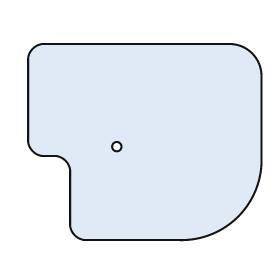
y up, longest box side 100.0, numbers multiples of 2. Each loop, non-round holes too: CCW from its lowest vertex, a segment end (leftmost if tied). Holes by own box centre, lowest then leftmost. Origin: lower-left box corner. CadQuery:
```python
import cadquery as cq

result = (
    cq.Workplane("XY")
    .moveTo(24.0, 0.0)
    .lineTo(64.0, 0.0)
    .threePointArc((90.0, 10.0), (100.0, 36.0))
    .lineTo(100.0, 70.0)
    .threePointArc((96.0, 80.0), (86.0, 84.0))
    .lineTo(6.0, 84.0)
    .threePointArc((2.0, 82.0), (0.0, 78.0))
    .lineTo(0.0, 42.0)
    .threePointArc((2.0, 38.0), (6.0, 36.0))
    .lineTo(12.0, 36.0)
    .threePointArc((16.0, 34.0), (18.0, 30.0))
    .lineTo(18.0, 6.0)
    .threePointArc((20.0, 2.0), (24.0, 0.0))
    .close()
    .moveTo(38.0, 40.0)
    .circle(2.0)
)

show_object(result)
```